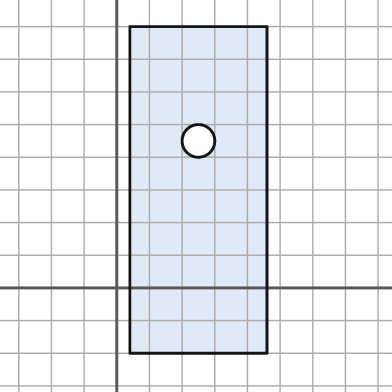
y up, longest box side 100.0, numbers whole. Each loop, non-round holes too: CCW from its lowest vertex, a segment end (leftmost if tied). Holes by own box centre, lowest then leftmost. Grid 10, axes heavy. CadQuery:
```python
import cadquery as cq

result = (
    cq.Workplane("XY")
    .moveTo(4.0, -20.0)
    .lineTo(46.0, -20.0)
    .lineTo(46.0, 80.0)
    .lineTo(4.0, 80.0)
    .close()
    .moveTo(25.0, 45.0)
    .circle(5.0)
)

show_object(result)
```